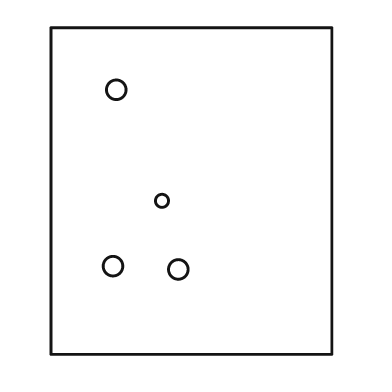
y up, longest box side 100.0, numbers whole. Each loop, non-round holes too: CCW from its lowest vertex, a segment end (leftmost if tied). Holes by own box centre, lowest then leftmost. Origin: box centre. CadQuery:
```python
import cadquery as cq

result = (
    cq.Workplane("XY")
    .moveTo(-43.0, -50.0)
    .lineTo(43.0, -50.0)
    .lineTo(43.0, 50.0)
    .lineTo(-43.0, 50.0)
    .close()
    .moveTo(-4.0, -24.0)
    .circle(3.0)
    .moveTo(-24.0, -23.0)
    .circle(3.0)
    .moveTo(-9.0, -3.0)
    .circle(2.0)
    .moveTo(-23.0, 31.0)
    .circle(3.0)
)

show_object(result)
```